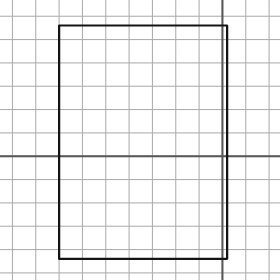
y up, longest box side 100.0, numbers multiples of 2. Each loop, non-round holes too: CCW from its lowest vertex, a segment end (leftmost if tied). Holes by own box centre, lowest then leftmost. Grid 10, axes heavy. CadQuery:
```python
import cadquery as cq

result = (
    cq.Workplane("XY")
    .moveTo(-70.0, -44.0)
    .lineTo(2.0, -44.0)
    .lineTo(2.0, 56.0)
    .lineTo(-70.0, 56.0)
    .close()
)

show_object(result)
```